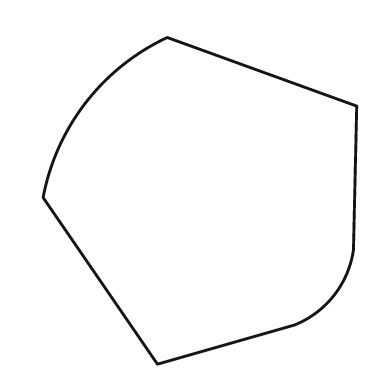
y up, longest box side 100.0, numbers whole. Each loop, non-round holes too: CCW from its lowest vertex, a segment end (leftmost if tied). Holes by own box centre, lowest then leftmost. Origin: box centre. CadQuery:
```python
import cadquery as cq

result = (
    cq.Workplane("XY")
    .moveTo(-13.0, -50.0)
    .lineTo(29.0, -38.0)
    .threePointArc((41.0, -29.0), (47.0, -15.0))
    .lineTo(48.0, 29.0)
    .lineTo(-10.0, 50.0)
    .threePointArc((-35.0, 30.0), (-48.0, 1.0))
    .close()
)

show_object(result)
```